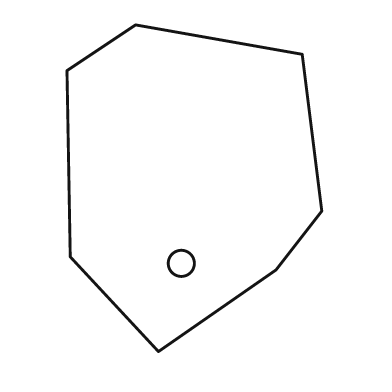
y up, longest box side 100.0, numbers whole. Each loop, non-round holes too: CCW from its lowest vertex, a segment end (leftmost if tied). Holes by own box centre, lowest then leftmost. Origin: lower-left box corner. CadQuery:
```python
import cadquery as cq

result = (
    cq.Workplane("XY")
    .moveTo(28.0, 0.0)
    .lineTo(64.0, 25.0)
    .lineTo(78.0, 43.0)
    .lineTo(72.0, 91.0)
    .lineTo(21.0, 100.0)
    .lineTo(0.0, 86.0)
    .lineTo(1.0, 29.0)
    .close()
    .moveTo(35.0, 27.0)
    .circle(4.0)
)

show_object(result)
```